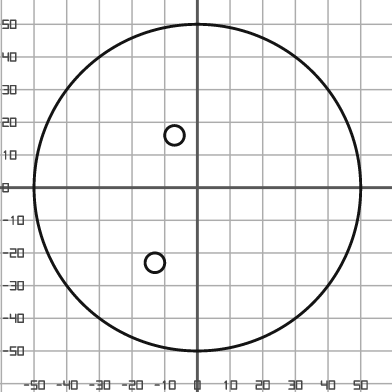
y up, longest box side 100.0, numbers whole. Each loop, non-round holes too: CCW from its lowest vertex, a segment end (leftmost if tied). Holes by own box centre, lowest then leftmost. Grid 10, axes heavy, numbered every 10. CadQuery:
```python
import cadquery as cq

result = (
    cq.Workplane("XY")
    .moveTo(0.0, 0.0)
    .circle(50.0)
    .moveTo(-13.0, -23.0)
    .circle(3.0)
    .moveTo(-7.0, 16.0)
    .circle(3.0)
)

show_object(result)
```